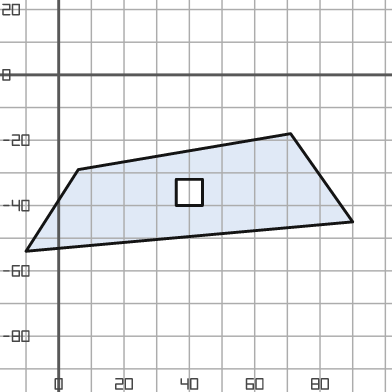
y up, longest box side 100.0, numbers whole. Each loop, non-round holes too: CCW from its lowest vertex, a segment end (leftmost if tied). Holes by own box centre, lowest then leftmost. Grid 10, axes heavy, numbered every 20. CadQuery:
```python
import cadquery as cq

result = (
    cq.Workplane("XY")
    .moveTo(-10.0, -54.0)
    .lineTo(90.0, -45.0)
    .lineTo(71.0, -18.0)
    .lineTo(6.0, -29.0)
    .close()
    .moveTo(36.0, -40.0)
    .lineTo(44.0, -40.0)
    .lineTo(44.0, -32.0)
    .lineTo(36.0, -32.0)
    .close()
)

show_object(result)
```